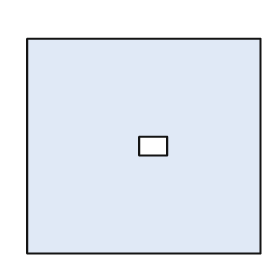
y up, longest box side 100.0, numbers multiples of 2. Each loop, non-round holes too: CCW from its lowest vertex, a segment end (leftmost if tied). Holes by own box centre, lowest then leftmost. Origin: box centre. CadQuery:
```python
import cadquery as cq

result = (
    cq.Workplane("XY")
    .moveTo(-50.0, -46.0)
    .lineTo(50.0, -46.0)
    .lineTo(50.0, 46.0)
    .lineTo(-50.0, 46.0)
    .close()
    .moveTo(-2.0, -4.0)
    .lineTo(10.0, -4.0)
    .lineTo(10.0, 4.0)
    .lineTo(-2.0, 4.0)
    .close()
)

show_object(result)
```